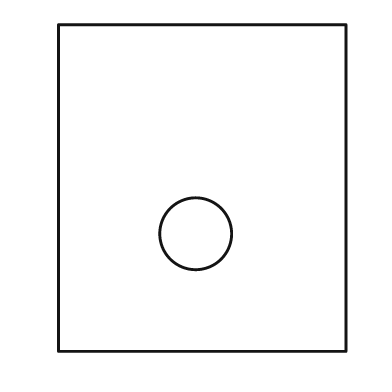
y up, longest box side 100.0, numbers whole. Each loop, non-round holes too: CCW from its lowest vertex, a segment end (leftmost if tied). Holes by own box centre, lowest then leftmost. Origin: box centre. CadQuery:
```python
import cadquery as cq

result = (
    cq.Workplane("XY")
    .moveTo(-44.0, -50.0)
    .lineTo(44.0, -50.0)
    .lineTo(44.0, 50.0)
    .lineTo(-44.0, 50.0)
    .close()
    .moveTo(-2.0, -14.0)
    .circle(11.0)
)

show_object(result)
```